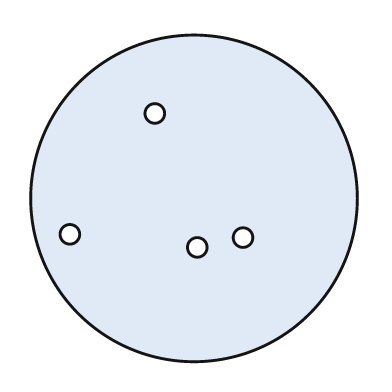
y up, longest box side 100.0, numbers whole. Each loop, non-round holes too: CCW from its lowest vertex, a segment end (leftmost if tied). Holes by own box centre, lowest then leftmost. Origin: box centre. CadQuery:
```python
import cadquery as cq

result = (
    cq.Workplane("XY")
    .moveTo(0.0, 0.0)
    .circle(50.0)
    .moveTo(1.0, -15.0)
    .circle(3.0)
    .moveTo(15.0, -12.0)
    .circle(3.0)
    .moveTo(-38.0, -11.0)
    .circle(3.0)
    .moveTo(-12.0, 26.0)
    .circle(3.0)
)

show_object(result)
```